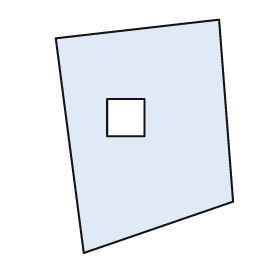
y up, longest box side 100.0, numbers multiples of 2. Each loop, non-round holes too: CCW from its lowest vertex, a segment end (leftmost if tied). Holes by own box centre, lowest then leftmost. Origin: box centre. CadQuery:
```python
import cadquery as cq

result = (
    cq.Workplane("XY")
    .moveTo(-26.0, -50.0)
    .lineTo(38.0, -28.0)
    .lineTo(32.0, 50.0)
    .lineTo(-38.0, 42.0)
    .close()
    .moveTo(-16.0, 0.0)
    .lineTo(0.0, 0.0)
    .lineTo(0.0, 16.0)
    .lineTo(-16.0, 16.0)
    .close()
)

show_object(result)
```